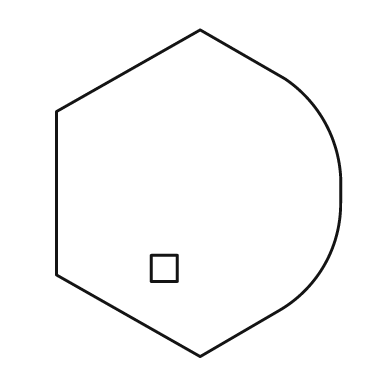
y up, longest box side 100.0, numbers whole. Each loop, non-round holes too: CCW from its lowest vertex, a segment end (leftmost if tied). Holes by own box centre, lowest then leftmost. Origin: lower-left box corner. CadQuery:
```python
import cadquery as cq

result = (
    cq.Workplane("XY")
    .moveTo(44.0, 0.0)
    .lineTo(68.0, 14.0)
    .threePointArc((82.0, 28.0), (87.0, 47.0))
    .lineTo(87.0, 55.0)
    .threePointArc((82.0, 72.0), (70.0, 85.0))
    .lineTo(44.0, 100.0)
    .lineTo(0.0, 75.0)
    .lineTo(0.0, 25.0)
    .close()
    .moveTo(29.0, 23.0)
    .lineTo(37.0, 23.0)
    .lineTo(37.0, 31.0)
    .lineTo(29.0, 31.0)
    .close()
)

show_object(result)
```